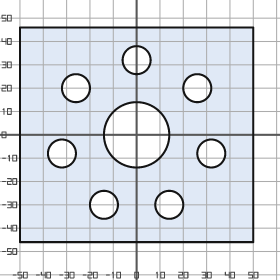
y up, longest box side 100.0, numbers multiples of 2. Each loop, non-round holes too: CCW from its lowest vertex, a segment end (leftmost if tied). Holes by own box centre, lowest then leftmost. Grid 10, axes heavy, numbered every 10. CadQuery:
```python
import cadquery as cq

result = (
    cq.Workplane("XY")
    .moveTo(-50.0, -46.0)
    .lineTo(50.0, -46.0)
    .lineTo(50.0, 46.0)
    .lineTo(-50.0, 46.0)
    .close()
    .moveTo(-14.0, -30.0)
    .circle(6.0)
    .moveTo(14.0, -30.0)
    .circle(6.0)
    .moveTo(-32.0, -8.0)
    .circle(6.0)
    .moveTo(32.0, -8.0)
    .circle(6.0)
    .moveTo(0.0, 0.0)
    .circle(14.0)
    .moveTo(-26.0, 20.0)
    .circle(6.0)
    .moveTo(26.0, 20.0)
    .circle(6.0)
    .moveTo(0.0, 32.0)
    .circle(6.0)
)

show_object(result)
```